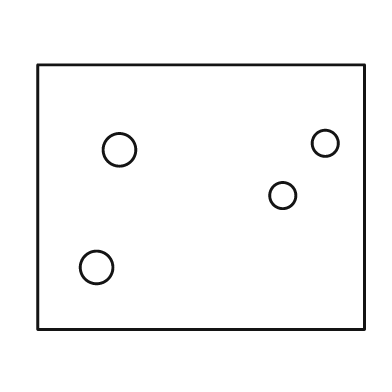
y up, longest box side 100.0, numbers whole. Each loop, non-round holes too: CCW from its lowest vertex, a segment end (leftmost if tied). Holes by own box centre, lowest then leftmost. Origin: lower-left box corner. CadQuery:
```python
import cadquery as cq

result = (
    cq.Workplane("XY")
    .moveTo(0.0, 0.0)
    .lineTo(100.0, 0.0)
    .lineTo(100.0, 81.0)
    .lineTo(0.0, 81.0)
    .close()
    .moveTo(18.0, 19.0)
    .circle(5.0)
    .moveTo(75.0, 41.0)
    .circle(4.0)
    .moveTo(25.0, 55.0)
    .circle(5.0)
    .moveTo(88.0, 57.0)
    .circle(4.0)
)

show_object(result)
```